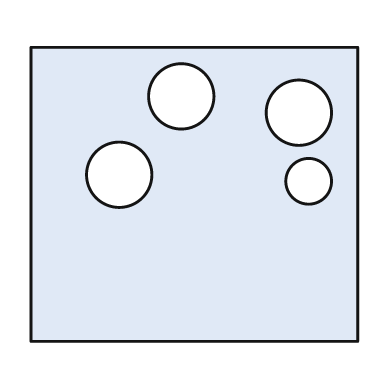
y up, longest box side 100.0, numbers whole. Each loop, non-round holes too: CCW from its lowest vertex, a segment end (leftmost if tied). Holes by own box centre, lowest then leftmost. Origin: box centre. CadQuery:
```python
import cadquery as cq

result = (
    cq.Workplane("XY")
    .moveTo(-50.0, -45.0)
    .lineTo(50.0, -45.0)
    .lineTo(50.0, 45.0)
    .lineTo(-50.0, 45.0)
    .close()
    .moveTo(35.0, 4.0)
    .circle(7.0)
    .moveTo(-23.0, 6.0)
    .circle(10.0)
    .moveTo(32.0, 25.0)
    .circle(10.0)
    .moveTo(-4.0, 30.0)
    .circle(10.0)
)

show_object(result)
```